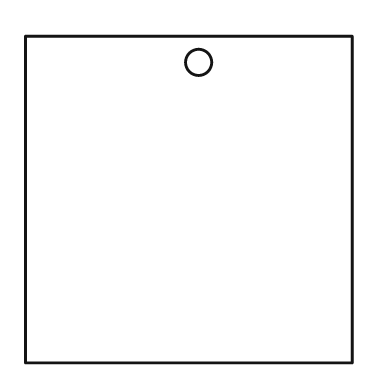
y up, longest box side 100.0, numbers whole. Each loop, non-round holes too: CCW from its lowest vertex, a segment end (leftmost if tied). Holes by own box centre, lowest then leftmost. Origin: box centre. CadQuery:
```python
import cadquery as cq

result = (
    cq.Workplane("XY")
    .moveTo(-50.0, -50.0)
    .lineTo(50.0, -50.0)
    .lineTo(50.0, 50.0)
    .lineTo(-50.0, 50.0)
    .close()
    .moveTo(3.0, 42.0)
    .circle(4.0)
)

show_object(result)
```